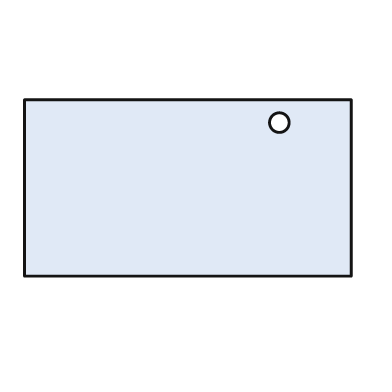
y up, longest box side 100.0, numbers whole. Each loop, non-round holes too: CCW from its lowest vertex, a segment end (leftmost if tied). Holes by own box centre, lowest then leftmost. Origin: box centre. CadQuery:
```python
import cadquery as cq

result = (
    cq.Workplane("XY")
    .moveTo(-50.0, -27.0)
    .lineTo(50.0, -27.0)
    .lineTo(50.0, 27.0)
    .lineTo(-50.0, 27.0)
    .close()
    .moveTo(28.0, 20.0)
    .circle(3.0)
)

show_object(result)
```